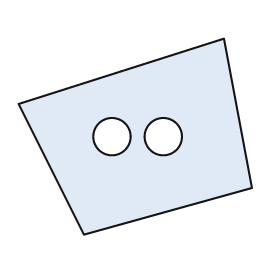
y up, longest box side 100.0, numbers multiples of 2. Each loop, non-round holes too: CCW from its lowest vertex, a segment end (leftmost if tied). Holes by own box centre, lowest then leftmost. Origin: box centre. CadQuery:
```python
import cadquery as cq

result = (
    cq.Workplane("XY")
    .moveTo(-22.0, -42.0)
    .lineTo(50.0, -22.0)
    .lineTo(38.0, 42.0)
    .lineTo(-50.0, 14.0)
    .close()
    .moveTo(-10.0, 0.0)
    .circle(8.0)
    .moveTo(12.0, 0.0)
    .circle(8.0)
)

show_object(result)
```